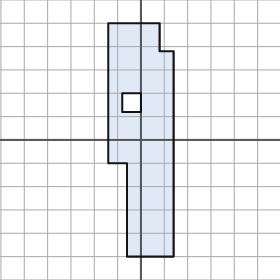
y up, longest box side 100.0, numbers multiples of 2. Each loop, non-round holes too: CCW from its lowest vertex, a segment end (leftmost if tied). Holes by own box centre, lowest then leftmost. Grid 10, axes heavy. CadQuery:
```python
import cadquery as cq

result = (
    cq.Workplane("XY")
    .moveTo(-6.0, -50.0)
    .lineTo(14.0, -50.0)
    .lineTo(14.0, 38.0)
    .lineTo(8.0, 38.0)
    .lineTo(8.0, 50.0)
    .lineTo(-14.0, 50.0)
    .lineTo(-14.0, -10.0)
    .lineTo(-6.0, -10.0)
    .close()
    .moveTo(-8.0, 12.0)
    .lineTo(0.0, 12.0)
    .lineTo(0.0, 20.0)
    .lineTo(-8.0, 20.0)
    .close()
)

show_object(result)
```